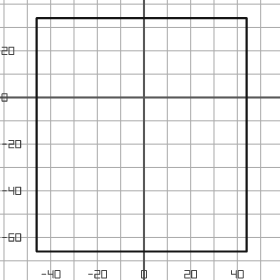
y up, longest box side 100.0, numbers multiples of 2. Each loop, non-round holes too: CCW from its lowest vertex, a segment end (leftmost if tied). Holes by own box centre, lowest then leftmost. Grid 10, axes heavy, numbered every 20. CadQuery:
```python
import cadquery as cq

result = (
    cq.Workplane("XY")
    .moveTo(-46.0, -66.0)
    .lineTo(44.0, -66.0)
    .lineTo(44.0, 34.0)
    .lineTo(-46.0, 34.0)
    .close()
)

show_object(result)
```